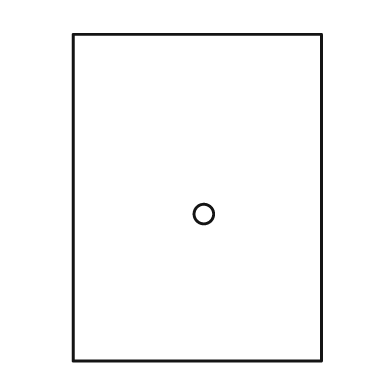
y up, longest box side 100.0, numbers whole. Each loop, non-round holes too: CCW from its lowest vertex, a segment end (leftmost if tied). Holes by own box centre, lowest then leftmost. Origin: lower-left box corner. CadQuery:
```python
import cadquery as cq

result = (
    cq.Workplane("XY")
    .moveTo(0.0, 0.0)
    .lineTo(76.0, 0.0)
    .lineTo(76.0, 100.0)
    .lineTo(0.0, 100.0)
    .close()
    .moveTo(40.0, 45.0)
    .circle(3.0)
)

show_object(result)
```